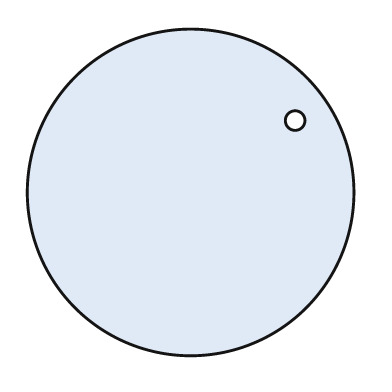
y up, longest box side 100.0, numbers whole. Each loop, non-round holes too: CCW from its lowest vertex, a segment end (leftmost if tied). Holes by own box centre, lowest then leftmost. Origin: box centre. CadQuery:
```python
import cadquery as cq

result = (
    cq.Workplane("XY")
    .moveTo(0.0, 0.0)
    .circle(50.0)
    .moveTo(32.0, 22.0)
    .circle(3.0)
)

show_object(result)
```